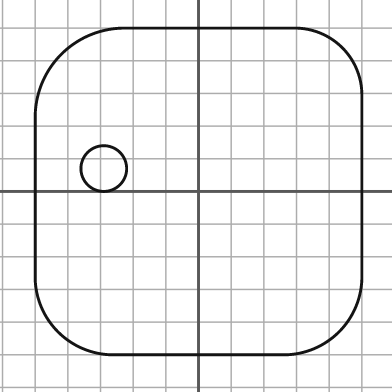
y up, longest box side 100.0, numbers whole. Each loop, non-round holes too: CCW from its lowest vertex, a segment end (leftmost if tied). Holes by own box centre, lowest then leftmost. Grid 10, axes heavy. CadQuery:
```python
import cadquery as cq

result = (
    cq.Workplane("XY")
    .moveTo(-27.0, -50.0)
    .lineTo(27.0, -50.0)
    .threePointArc((43.0, -43.0), (50.0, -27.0))
    .lineTo(50.0, 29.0)
    .threePointArc((44.0, 44.0), (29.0, 50.0))
    .lineTo(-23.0, 50.0)
    .threePointArc((-42.0, 42.0), (-50.0, 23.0))
    .lineTo(-50.0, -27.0)
    .threePointArc((-43.0, -43.0), (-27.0, -50.0))
    .close()
    .moveTo(-29.0, 7.0)
    .circle(7.0)
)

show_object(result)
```